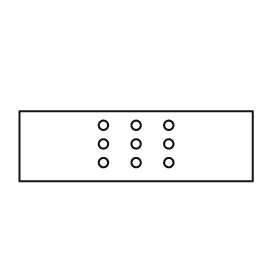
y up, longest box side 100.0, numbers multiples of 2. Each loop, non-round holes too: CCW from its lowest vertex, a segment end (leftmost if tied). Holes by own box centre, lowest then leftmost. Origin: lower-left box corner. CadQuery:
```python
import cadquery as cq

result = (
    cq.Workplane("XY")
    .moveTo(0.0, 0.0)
    .lineTo(100.0, 0.0)
    .lineTo(100.0, 30.0)
    .lineTo(0.0, 30.0)
    .close()
    .moveTo(36.0, 8.0)
    .circle(2.0)
    .moveTo(50.0, 8.0)
    .circle(2.0)
    .moveTo(64.0, 8.0)
    .circle(2.0)
    .moveTo(36.0, 16.0)
    .circle(2.0)
    .moveTo(50.0, 16.0)
    .circle(2.0)
    .moveTo(64.0, 16.0)
    .circle(2.0)
    .moveTo(36.0, 24.0)
    .circle(2.0)
    .moveTo(50.0, 24.0)
    .circle(2.0)
    .moveTo(64.0, 24.0)
    .circle(2.0)
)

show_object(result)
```